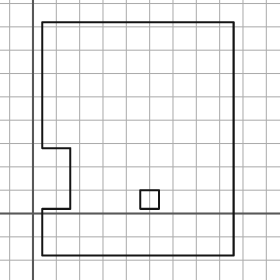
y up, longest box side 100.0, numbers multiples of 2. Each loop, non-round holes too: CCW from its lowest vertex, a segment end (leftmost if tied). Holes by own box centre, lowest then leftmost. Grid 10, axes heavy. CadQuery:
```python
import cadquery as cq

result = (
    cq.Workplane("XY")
    .moveTo(4.0, -18.0)
    .lineTo(86.0, -18.0)
    .lineTo(86.0, 82.0)
    .lineTo(4.0, 82.0)
    .lineTo(4.0, 28.0)
    .lineTo(16.0, 28.0)
    .lineTo(16.0, 2.0)
    .lineTo(4.0, 2.0)
    .close()
    .moveTo(46.0, 2.0)
    .lineTo(54.0, 2.0)
    .lineTo(54.0, 10.0)
    .lineTo(46.0, 10.0)
    .close()
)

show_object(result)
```